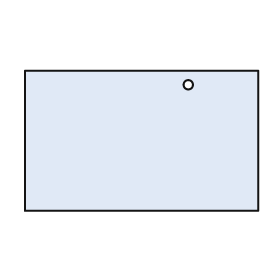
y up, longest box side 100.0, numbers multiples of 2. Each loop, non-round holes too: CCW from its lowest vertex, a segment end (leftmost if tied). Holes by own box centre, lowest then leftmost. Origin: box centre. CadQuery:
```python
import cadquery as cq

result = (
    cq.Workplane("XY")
    .moveTo(-50.0, -30.0)
    .lineTo(50.0, -30.0)
    .lineTo(50.0, 30.0)
    .lineTo(-50.0, 30.0)
    .close()
    .moveTo(20.0, 24.0)
    .circle(2.0)
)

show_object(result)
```